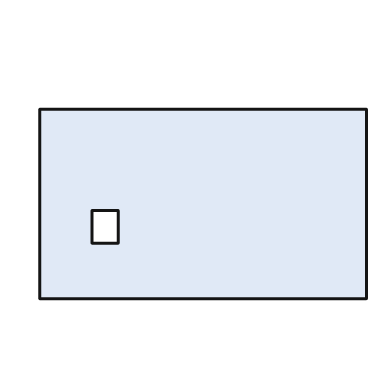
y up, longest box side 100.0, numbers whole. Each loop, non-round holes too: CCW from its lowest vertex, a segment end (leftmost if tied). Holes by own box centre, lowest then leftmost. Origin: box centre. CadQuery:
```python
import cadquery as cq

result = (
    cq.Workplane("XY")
    .moveTo(-50.0, -29.0)
    .lineTo(50.0, -29.0)
    .lineTo(50.0, 29.0)
    .lineTo(-50.0, 29.0)
    .close()
    .moveTo(-34.0, -12.0)
    .lineTo(-26.0, -12.0)
    .lineTo(-26.0, -2.0)
    .lineTo(-34.0, -2.0)
    .close()
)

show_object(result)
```